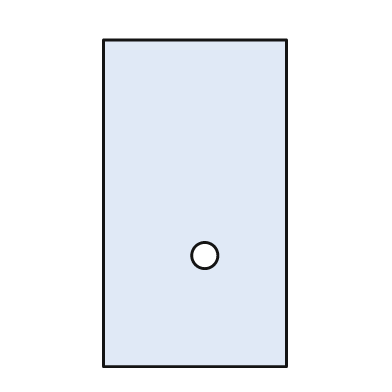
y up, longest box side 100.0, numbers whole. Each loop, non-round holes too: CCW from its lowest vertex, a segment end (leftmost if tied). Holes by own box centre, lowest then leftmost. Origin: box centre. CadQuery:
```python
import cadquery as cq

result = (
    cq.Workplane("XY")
    .moveTo(-28.0, -50.0)
    .lineTo(28.0, -50.0)
    .lineTo(28.0, 50.0)
    .lineTo(-28.0, 50.0)
    .close()
    .moveTo(3.0, -16.0)
    .circle(4.0)
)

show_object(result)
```